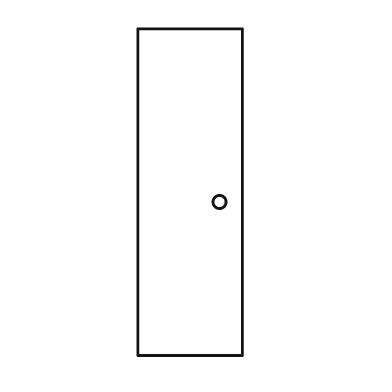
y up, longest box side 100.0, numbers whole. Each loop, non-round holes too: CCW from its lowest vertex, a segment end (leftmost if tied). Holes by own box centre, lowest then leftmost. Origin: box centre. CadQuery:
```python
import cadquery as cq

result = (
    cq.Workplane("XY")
    .moveTo(-16.0, -50.0)
    .lineTo(16.0, -50.0)
    .lineTo(16.0, 50.0)
    .lineTo(-16.0, 50.0)
    .close()
    .moveTo(9.0, -3.0)
    .circle(2.0)
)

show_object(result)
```